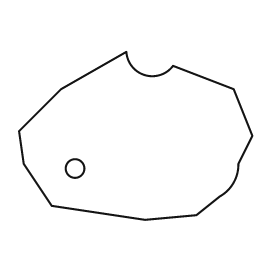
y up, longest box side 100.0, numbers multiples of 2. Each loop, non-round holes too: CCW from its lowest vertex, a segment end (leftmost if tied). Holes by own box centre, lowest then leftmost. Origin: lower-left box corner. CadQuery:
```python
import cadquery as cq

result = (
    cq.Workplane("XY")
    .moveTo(54.0, 0.0)
    .lineTo(76.0, 2.0)
    .lineTo(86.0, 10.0)
    .threePointArc((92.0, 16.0), (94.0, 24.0))
    .lineTo(100.0, 36.0)
    .lineTo(92.0, 56.0)
    .lineTo(66.0, 66.0)
    .threePointArc((54.0, 62.0), (46.0, 72.0))
    .lineTo(18.0, 56.0)
    .lineTo(0.0, 38.0)
    .lineTo(2.0, 24.0)
    .lineTo(14.0, 6.0)
    .close()
    .moveTo(24.0, 22.0)
    .circle(4.0)
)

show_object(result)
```